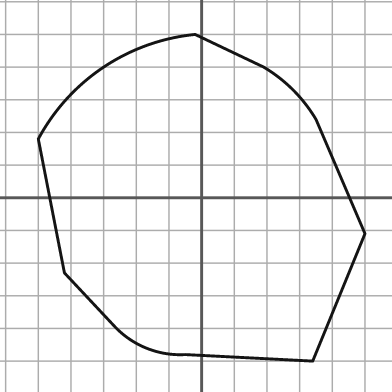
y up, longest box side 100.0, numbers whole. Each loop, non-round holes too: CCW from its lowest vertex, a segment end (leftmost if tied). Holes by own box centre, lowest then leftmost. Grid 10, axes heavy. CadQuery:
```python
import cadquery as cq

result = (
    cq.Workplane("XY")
    .moveTo(34.0, -50.0)
    .lineTo(50.0, -11.0)
    .lineTo(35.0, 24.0)
    .threePointArc((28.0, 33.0), (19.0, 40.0))
    .lineTo(-2.0, 50.0)
    .threePointArc((-30.0, 40.0), (-50.0, 18.0))
    .lineTo(-42.0, -23.0)
    .lineTo(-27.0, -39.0)
    .threePointArc((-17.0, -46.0), (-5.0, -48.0))
    .close()
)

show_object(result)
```